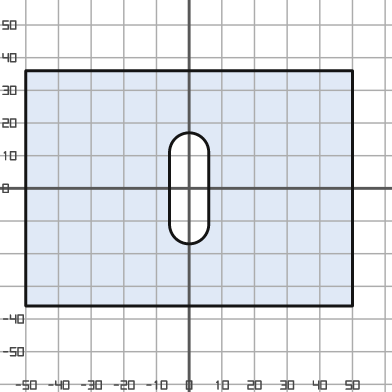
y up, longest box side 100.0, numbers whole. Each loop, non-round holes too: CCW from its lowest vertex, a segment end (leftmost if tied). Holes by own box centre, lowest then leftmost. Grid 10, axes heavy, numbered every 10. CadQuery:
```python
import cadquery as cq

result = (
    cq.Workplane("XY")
    .moveTo(-50.0, -36.0)
    .lineTo(50.0, -36.0)
    .lineTo(50.0, 36.0)
    .lineTo(-50.0, 36.0)
    .close()
    .moveTo(-6.0, -11.0)
    .threePointArc((0.0, -17.0), (6.0, -11.0))
    .lineTo(6.0, 11.0)
    .threePointArc((0.0, 17.0), (-6.0, 11.0))
    .close()
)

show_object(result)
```